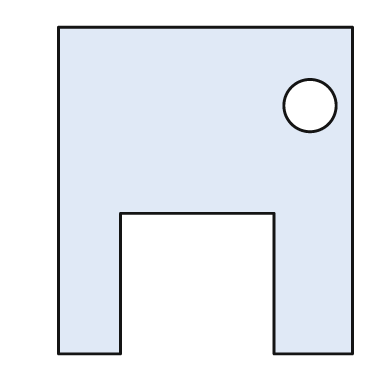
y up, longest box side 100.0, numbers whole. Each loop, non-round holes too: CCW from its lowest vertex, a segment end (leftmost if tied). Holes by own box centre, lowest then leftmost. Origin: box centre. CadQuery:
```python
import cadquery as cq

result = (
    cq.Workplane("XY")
    .moveTo(-45.0, -50.0)
    .lineTo(-26.0, -50.0)
    .lineTo(-26.0, -7.0)
    .lineTo(21.0, -7.0)
    .lineTo(21.0, -50.0)
    .lineTo(45.0, -50.0)
    .lineTo(45.0, 50.0)
    .lineTo(-45.0, 50.0)
    .close()
    .moveTo(32.0, 26.0)
    .circle(8.0)
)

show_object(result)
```